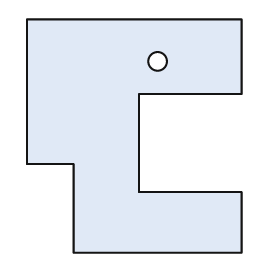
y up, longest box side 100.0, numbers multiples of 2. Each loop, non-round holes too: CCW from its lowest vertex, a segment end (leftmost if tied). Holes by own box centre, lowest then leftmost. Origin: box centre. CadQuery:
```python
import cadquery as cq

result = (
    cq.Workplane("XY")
    .moveTo(-26.0, -50.0)
    .lineTo(46.0, -50.0)
    .lineTo(46.0, -24.0)
    .lineTo(2.0, -24.0)
    .lineTo(2.0, 18.0)
    .lineTo(46.0, 18.0)
    .lineTo(46.0, 50.0)
    .lineTo(-46.0, 50.0)
    .lineTo(-46.0, -12.0)
    .lineTo(-26.0, -12.0)
    .close()
    .moveTo(10.0, 32.0)
    .circle(4.0)
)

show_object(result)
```